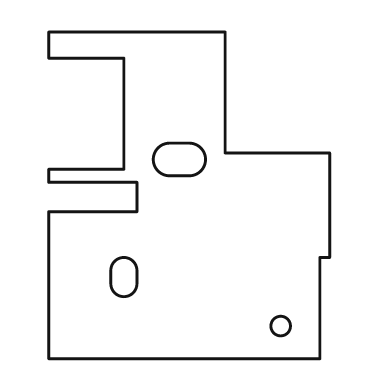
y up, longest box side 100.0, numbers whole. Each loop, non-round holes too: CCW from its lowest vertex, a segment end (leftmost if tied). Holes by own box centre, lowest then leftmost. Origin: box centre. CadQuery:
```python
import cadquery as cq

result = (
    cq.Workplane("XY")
    .moveTo(-43.0, -50.0)
    .lineTo(40.0, -50.0)
    .lineTo(40.0, -19.0)
    .lineTo(43.0, -19.0)
    .lineTo(43.0, 13.0)
    .lineTo(11.0, 13.0)
    .lineTo(11.0, 50.0)
    .lineTo(-43.0, 50.0)
    .lineTo(-43.0, 42.0)
    .lineTo(-20.0, 42.0)
    .lineTo(-20.0, 8.0)
    .lineTo(-43.0, 8.0)
    .lineTo(-43.0, 4.0)
    .lineTo(-16.0, 4.0)
    .lineTo(-16.0, -5.0)
    .lineTo(-43.0, -5.0)
    .close()
    .moveTo(28.0, -40.0)
    .circle(3.0)
    .moveTo(-24.0, -27.0)
    .threePointArc((-20.0, -31.0), (-16.0, -27.0))
    .lineTo(-16.0, -23.0)
    .threePointArc((-20.0, -19.0), (-24.0, -23.0))
    .close()
    .moveTo(-6.0, 6.0)
    .lineTo(0.0, 6.0)
    .threePointArc((5.0, 11.0), (0.0, 16.0))
    .lineTo(-6.0, 16.0)
    .threePointArc((-11.0, 11.0), (-6.0, 6.0))
    .close()
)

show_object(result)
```